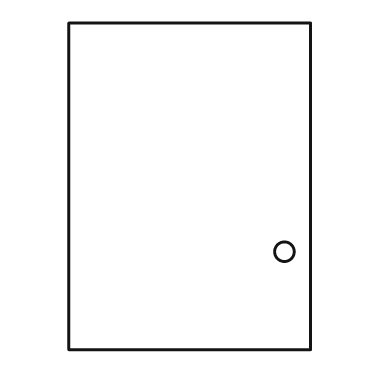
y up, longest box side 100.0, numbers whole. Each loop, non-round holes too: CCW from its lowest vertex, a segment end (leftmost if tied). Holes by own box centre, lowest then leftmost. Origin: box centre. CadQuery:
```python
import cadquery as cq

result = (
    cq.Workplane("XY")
    .moveTo(-37.0, -50.0)
    .lineTo(37.0, -50.0)
    .lineTo(37.0, 50.0)
    .lineTo(-37.0, 50.0)
    .close()
    .moveTo(29.0, -20.0)
    .circle(3.0)
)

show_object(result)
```